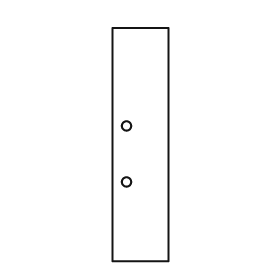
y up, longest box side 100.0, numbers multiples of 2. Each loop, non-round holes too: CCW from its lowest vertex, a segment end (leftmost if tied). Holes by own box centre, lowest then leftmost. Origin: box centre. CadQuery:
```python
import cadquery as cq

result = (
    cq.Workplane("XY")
    .moveTo(-12.0, -50.0)
    .lineTo(12.0, -50.0)
    .lineTo(12.0, 50.0)
    .lineTo(-12.0, 50.0)
    .close()
    .moveTo(-6.0, -16.0)
    .circle(2.0)
    .moveTo(-6.0, 8.0)
    .circle(2.0)
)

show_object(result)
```